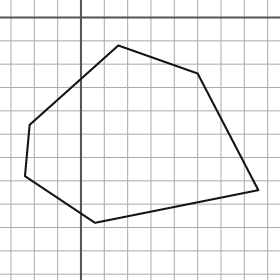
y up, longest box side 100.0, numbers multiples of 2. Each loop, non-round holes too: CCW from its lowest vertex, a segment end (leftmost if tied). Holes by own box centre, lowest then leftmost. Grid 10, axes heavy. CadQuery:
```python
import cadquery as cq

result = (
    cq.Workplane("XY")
    .moveTo(6.0, -88.0)
    .lineTo(76.0, -74.0)
    .lineTo(50.0, -24.0)
    .lineTo(16.0, -12.0)
    .lineTo(-22.0, -46.0)
    .lineTo(-24.0, -68.0)
    .close()
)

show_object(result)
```